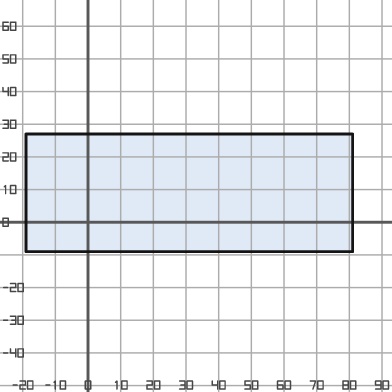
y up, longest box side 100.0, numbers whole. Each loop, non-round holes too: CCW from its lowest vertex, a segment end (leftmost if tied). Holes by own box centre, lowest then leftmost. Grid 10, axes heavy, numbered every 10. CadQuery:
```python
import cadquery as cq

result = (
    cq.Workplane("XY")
    .moveTo(-19.0, -9.0)
    .lineTo(81.0, -9.0)
    .lineTo(81.0, 27.0)
    .lineTo(-19.0, 27.0)
    .close()
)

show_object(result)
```